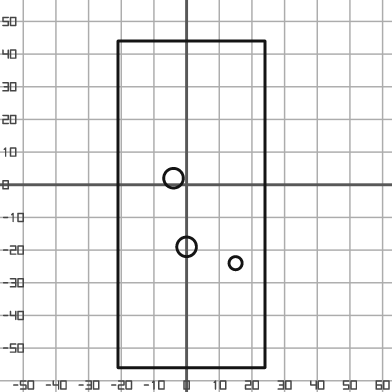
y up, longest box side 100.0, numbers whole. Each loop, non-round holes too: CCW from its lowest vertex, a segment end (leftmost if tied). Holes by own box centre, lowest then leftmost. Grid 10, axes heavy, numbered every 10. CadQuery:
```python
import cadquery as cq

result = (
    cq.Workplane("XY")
    .moveTo(-21.0, -56.0)
    .lineTo(24.0, -56.0)
    .lineTo(24.0, 44.0)
    .lineTo(-21.0, 44.0)
    .close()
    .moveTo(15.0, -24.0)
    .circle(2.0)
    .moveTo(0.0, -19.0)
    .circle(3.0)
    .moveTo(-4.0, 2.0)
    .circle(3.0)
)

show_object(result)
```